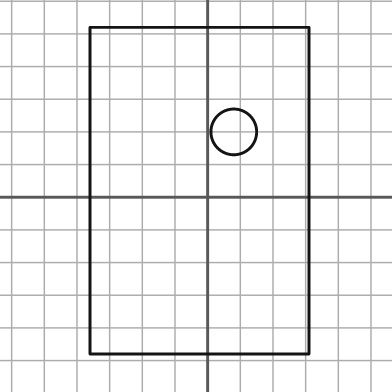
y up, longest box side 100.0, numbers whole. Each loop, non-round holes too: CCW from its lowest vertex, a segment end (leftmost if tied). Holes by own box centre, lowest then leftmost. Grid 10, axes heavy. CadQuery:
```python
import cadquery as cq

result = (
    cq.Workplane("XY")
    .moveTo(-36.0, -48.0)
    .lineTo(31.0, -48.0)
    .lineTo(31.0, 52.0)
    .lineTo(-36.0, 52.0)
    .close()
    .moveTo(8.0, 20.0)
    .circle(7.0)
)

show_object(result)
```